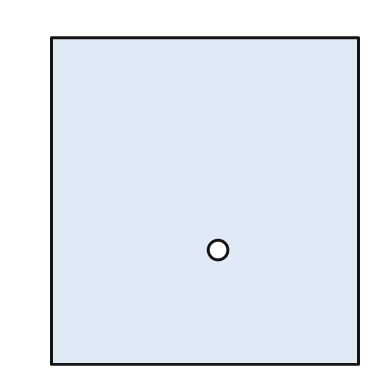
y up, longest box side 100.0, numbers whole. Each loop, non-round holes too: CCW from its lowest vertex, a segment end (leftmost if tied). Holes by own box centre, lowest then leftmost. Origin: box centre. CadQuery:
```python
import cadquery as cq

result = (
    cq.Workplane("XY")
    .moveTo(-47.0, -50.0)
    .lineTo(47.0, -50.0)
    .lineTo(47.0, 50.0)
    .lineTo(-47.0, 50.0)
    .close()
    .moveTo(4.0, -15.0)
    .circle(3.0)
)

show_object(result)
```